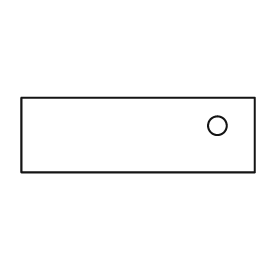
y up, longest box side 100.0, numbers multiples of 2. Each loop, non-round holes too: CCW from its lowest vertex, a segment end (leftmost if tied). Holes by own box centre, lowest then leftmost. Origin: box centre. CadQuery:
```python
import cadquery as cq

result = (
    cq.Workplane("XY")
    .moveTo(-50.0, -16.0)
    .lineTo(50.0, -16.0)
    .lineTo(50.0, 16.0)
    .lineTo(-50.0, 16.0)
    .close()
    .moveTo(34.0, 4.0)
    .circle(4.0)
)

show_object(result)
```